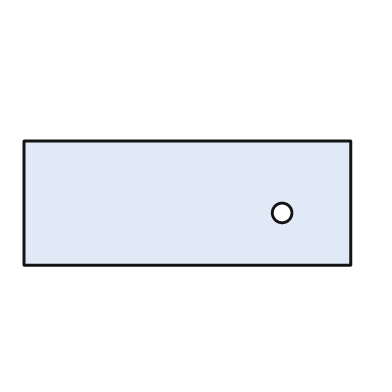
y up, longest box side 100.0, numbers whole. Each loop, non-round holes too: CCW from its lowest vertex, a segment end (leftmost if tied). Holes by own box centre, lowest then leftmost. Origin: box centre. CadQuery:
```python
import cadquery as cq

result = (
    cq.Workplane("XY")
    .moveTo(-50.0, -19.0)
    .lineTo(50.0, -19.0)
    .lineTo(50.0, 19.0)
    .lineTo(-50.0, 19.0)
    .close()
    .moveTo(29.0, -3.0)
    .circle(3.0)
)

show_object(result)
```